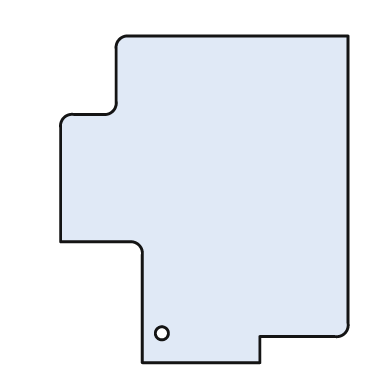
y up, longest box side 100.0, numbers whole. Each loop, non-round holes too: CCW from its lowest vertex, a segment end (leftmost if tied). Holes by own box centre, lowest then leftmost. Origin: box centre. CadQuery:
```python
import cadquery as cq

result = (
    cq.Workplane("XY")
    .moveTo(-19.0, -50.0)
    .lineTo(17.0, -50.0)
    .lineTo(17.0, -42.0)
    .lineTo(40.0, -42.0)
    .threePointArc((43.0, -41.0), (44.0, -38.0))
    .lineTo(44.0, 50.0)
    .lineTo(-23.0, 50.0)
    .threePointArc((-26.0, 49.0), (-27.0, 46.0))
    .lineTo(-27.0, 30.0)
    .threePointArc((-28.0, 27.0), (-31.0, 26.0))
    .lineTo(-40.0, 26.0)
    .threePointArc((-43.0, 25.0), (-44.0, 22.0))
    .lineTo(-44.0, -13.0)
    .lineTo(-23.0, -13.0)
    .threePointArc((-20.0, -14.0), (-19.0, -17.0))
    .close()
    .moveTo(-13.0, -41.0)
    .circle(2.0)
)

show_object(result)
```